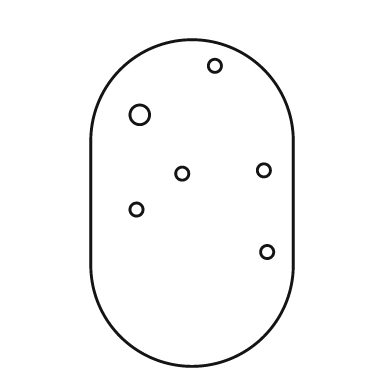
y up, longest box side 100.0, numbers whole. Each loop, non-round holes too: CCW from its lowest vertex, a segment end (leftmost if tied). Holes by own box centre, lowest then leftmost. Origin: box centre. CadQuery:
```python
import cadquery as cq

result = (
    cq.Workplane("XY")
    .moveTo(-31.0, -19.0)
    .threePointArc((0.0, -50.0), (31.0, -19.0))
    .lineTo(31.0, 19.0)
    .threePointArc((0.0, 50.0), (-31.0, 19.0))
    .close()
    .moveTo(23.0, -15.0)
    .circle(2.0)
    .moveTo(-17.0, -2.0)
    .circle(2.0)
    .moveTo(-3.0, 9.0)
    .circle(2.0)
    .moveTo(22.0, 10.0)
    .circle(2.0)
    .moveTo(-16.0, 27.0)
    .circle(3.0)
    .moveTo(7.0, 42.0)
    .circle(2.0)
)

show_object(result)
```